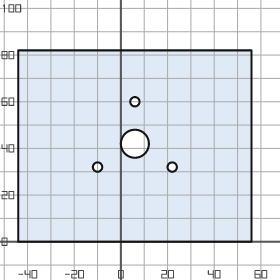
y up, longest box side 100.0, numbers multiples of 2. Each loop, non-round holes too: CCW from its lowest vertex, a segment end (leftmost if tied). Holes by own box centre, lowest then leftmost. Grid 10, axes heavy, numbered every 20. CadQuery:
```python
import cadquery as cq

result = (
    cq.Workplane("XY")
    .moveTo(-44.0, 0.0)
    .lineTo(56.0, 0.0)
    .lineTo(56.0, 82.0)
    .lineTo(-44.0, 82.0)
    .close()
    .moveTo(-10.0, 32.0)
    .circle(2.0)
    .moveTo(22.0, 32.0)
    .circle(2.0)
    .moveTo(6.0, 42.0)
    .circle(6.0)
    .moveTo(6.0, 60.0)
    .circle(2.0)
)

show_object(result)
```